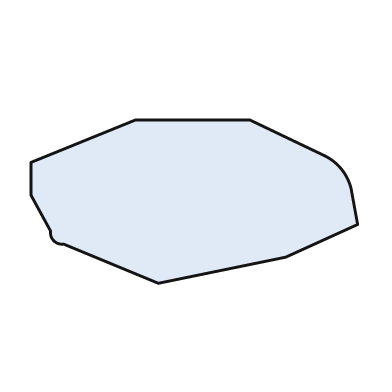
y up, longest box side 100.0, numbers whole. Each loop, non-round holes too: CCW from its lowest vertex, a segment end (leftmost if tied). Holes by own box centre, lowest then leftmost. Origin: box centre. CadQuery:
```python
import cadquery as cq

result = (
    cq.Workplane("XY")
    .moveTo(-11.0, -25.0)
    .lineTo(28.0, -17.0)
    .lineTo(50.0, -7.0)
    .lineTo(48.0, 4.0)
    .threePointArc((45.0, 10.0), (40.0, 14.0))
    .lineTo(17.0, 25.0)
    .lineTo(-18.0, 25.0)
    .lineTo(-50.0, 12.0)
    .lineTo(-50.0, 2.0)
    .lineTo(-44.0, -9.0)
    .threePointArc((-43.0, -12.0), (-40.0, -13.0))
    .close()
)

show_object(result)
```